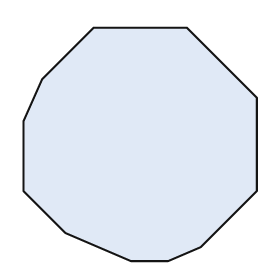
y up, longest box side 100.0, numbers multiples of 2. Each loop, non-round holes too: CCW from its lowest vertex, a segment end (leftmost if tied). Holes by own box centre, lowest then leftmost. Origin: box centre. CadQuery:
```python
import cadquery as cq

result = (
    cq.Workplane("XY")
    .moveTo(-4.0, -50.0)
    .lineTo(12.0, -50.0)
    .lineTo(26.0, -44.0)
    .lineTo(50.0, -20.0)
    .lineTo(50.0, 20.0)
    .lineTo(20.0, 50.0)
    .lineTo(-20.0, 50.0)
    .lineTo(-42.0, 28.0)
    .lineTo(-50.0, 10.0)
    .lineTo(-50.0, -20.0)
    .lineTo(-32.0, -38.0)
    .close()
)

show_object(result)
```